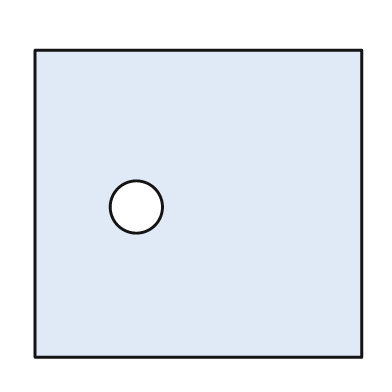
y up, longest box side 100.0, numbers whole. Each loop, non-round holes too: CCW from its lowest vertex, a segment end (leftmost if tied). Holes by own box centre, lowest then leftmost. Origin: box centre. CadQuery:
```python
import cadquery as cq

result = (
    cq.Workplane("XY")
    .moveTo(-50.0, -47.0)
    .lineTo(50.0, -47.0)
    .lineTo(50.0, 47.0)
    .lineTo(-50.0, 47.0)
    .close()
    .moveTo(-19.0, -1.0)
    .circle(8.0)
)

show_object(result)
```